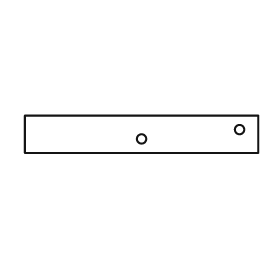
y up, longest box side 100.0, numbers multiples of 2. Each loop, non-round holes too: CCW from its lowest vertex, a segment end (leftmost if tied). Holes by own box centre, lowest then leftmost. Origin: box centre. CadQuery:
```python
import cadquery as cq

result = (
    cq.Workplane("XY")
    .moveTo(-50.0, -8.0)
    .lineTo(50.0, -8.0)
    .lineTo(50.0, 8.0)
    .lineTo(-50.0, 8.0)
    .close()
    .moveTo(0.0, -2.0)
    .circle(2.0)
    .moveTo(42.0, 2.0)
    .circle(2.0)
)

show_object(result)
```